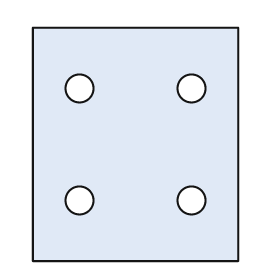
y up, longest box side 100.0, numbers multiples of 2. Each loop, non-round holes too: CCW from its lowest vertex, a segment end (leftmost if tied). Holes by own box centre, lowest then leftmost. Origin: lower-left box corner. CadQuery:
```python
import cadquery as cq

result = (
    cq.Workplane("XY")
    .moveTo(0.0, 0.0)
    .lineTo(88.0, 0.0)
    .lineTo(88.0, 100.0)
    .lineTo(0.0, 100.0)
    .close()
    .moveTo(20.0, 26.0)
    .circle(6.0)
    .moveTo(68.0, 26.0)
    .circle(6.0)
    .moveTo(20.0, 74.0)
    .circle(6.0)
    .moveTo(68.0, 74.0)
    .circle(6.0)
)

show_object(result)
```